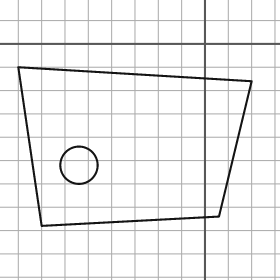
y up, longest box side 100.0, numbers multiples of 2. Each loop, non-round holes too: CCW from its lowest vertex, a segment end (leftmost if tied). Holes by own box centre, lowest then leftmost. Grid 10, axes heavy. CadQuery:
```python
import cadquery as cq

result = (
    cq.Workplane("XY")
    .moveTo(-70.0, -78.0)
    .lineTo(6.0, -74.0)
    .lineTo(20.0, -16.0)
    .lineTo(-80.0, -10.0)
    .close()
    .moveTo(-54.0, -52.0)
    .circle(8.0)
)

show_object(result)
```